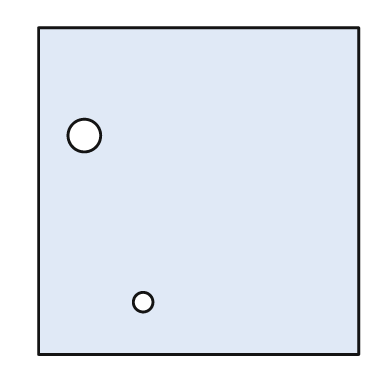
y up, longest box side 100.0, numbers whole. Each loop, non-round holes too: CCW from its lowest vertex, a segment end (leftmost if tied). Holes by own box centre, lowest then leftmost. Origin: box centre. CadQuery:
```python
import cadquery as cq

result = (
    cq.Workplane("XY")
    .moveTo(-49.0, -50.0)
    .lineTo(49.0, -50.0)
    .lineTo(49.0, 50.0)
    .lineTo(-49.0, 50.0)
    .close()
    .moveTo(-17.0, -34.0)
    .circle(3.0)
    .moveTo(-35.0, 17.0)
    .circle(5.0)
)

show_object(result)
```